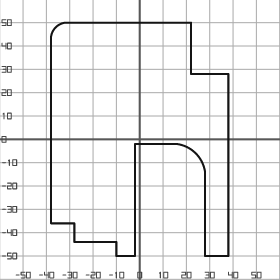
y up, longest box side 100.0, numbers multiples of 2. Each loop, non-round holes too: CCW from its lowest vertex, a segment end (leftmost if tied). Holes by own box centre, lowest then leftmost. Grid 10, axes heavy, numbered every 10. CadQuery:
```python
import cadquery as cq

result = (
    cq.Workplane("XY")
    .moveTo(-10.0, -50.0)
    .lineTo(-2.0, -50.0)
    .lineTo(-2.0, -2.0)
    .lineTo(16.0, -2.0)
    .threePointArc((24.0, -6.0), (28.0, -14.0))
    .lineTo(28.0, -50.0)
    .lineTo(38.0, -50.0)
    .lineTo(38.0, 28.0)
    .lineTo(22.0, 28.0)
    .lineTo(22.0, 50.0)
    .lineTo(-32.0, 50.0)
    .threePointArc((-36.0, 48.0), (-38.0, 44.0))
    .lineTo(-38.0, -36.0)
    .lineTo(-28.0, -36.0)
    .lineTo(-28.0, -44.0)
    .lineTo(-10.0, -44.0)
    .close()
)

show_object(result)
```